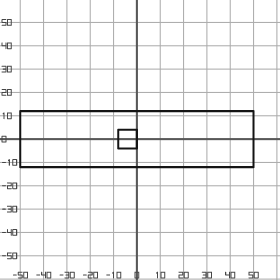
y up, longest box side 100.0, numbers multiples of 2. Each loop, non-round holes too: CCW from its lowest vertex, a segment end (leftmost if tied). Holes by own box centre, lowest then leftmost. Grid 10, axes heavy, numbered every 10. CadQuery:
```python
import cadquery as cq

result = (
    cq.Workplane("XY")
    .moveTo(-50.0, -12.0)
    .lineTo(50.0, -12.0)
    .lineTo(50.0, 12.0)
    .lineTo(-50.0, 12.0)
    .close()
    .moveTo(-8.0, -4.0)
    .lineTo(0.0, -4.0)
    .lineTo(0.0, 4.0)
    .lineTo(-8.0, 4.0)
    .close()
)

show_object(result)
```